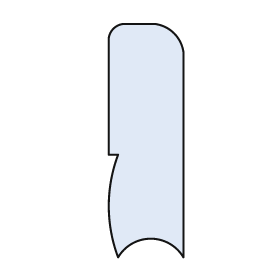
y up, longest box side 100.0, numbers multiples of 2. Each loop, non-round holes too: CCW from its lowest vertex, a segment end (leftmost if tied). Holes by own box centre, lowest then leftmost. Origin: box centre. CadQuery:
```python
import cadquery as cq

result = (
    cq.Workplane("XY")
    .moveTo(-12.0, -50.0)
    .threePointArc((2.0, -42.0), (16.0, -50.0))
    .lineTo(16.0, 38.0)
    .threePointArc((12.0, 46.0), (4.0, 50.0))
    .lineTo(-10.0, 50.0)
    .threePointArc((-14.0, 48.0), (-16.0, 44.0))
    .lineTo(-16.0, -6.0)
    .lineTo(-12.0, -6.0)
    .threePointArc((-16.0, -28.0), (-12.0, -50.0))
    .close()
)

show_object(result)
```